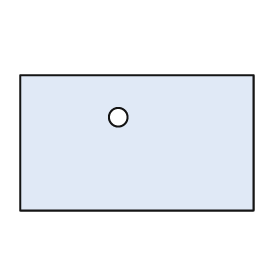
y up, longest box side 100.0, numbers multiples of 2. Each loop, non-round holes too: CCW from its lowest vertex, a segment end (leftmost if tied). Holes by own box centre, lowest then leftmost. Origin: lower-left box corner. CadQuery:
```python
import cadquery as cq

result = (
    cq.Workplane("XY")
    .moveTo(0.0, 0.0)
    .lineTo(100.0, 0.0)
    .lineTo(100.0, 58.0)
    .lineTo(0.0, 58.0)
    .close()
    .moveTo(42.0, 40.0)
    .circle(4.0)
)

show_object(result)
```